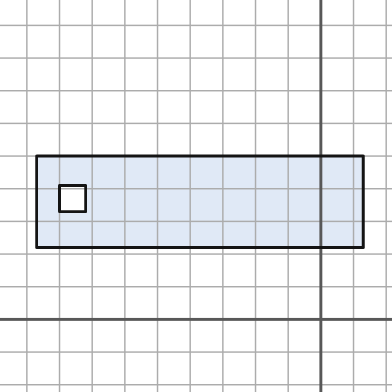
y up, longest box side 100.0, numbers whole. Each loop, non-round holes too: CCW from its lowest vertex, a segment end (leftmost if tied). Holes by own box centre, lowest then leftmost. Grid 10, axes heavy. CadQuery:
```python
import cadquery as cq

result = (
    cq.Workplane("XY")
    .moveTo(-87.0, 22.0)
    .lineTo(13.0, 22.0)
    .lineTo(13.0, 50.0)
    .lineTo(-87.0, 50.0)
    .close()
    .moveTo(-80.0, 33.0)
    .lineTo(-72.0, 33.0)
    .lineTo(-72.0, 41.0)
    .lineTo(-80.0, 41.0)
    .close()
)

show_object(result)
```